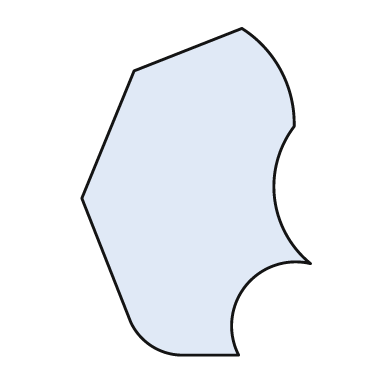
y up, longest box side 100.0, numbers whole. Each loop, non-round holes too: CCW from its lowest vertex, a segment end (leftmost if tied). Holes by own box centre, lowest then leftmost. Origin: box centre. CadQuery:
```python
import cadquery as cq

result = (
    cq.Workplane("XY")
    .moveTo(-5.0, -50.0)
    .lineTo(13.0, -50.0)
    .threePointArc((15.0, -29.0), (35.0, -22.0))
    .threePointArc((24.0, -2.0), (30.0, 20.0))
    .threePointArc((26.0, 37.0), (14.0, 50.0))
    .lineTo(-19.0, 37.0)
    .lineTo(-35.0, -2.0)
    .lineTo(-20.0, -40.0)
    .threePointArc((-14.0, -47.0), (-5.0, -50.0))
    .close()
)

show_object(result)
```